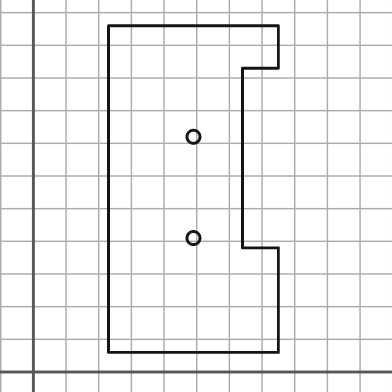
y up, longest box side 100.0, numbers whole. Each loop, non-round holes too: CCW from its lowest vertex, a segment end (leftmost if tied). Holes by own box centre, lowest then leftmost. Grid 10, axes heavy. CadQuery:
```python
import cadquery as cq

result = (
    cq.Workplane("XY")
    .moveTo(23.0, 6.0)
    .lineTo(75.0, 6.0)
    .lineTo(75.0, 38.0)
    .lineTo(64.0, 38.0)
    .lineTo(64.0, 93.0)
    .lineTo(75.0, 93.0)
    .lineTo(75.0, 106.0)
    .lineTo(23.0, 106.0)
    .close()
    .moveTo(49.0, 41.0)
    .circle(2.0)
    .moveTo(49.0, 72.0)
    .circle(2.0)
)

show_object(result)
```